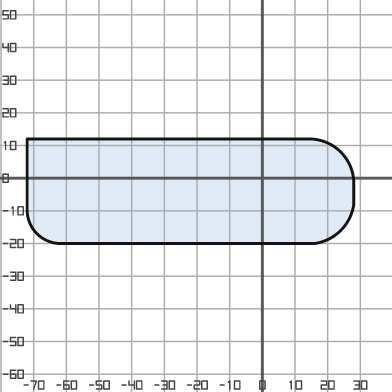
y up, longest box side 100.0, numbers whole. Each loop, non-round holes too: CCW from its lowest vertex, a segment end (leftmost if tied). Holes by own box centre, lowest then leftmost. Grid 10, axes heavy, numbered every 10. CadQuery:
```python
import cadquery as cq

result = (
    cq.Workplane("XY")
    .moveTo(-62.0, -20.0)
    .lineTo(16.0, -20.0)
    .threePointArc((24.0, -16.0), (28.0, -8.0))
    .lineTo(28.0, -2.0)
    .threePointArc((24.0, 8.0), (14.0, 12.0))
    .lineTo(-72.0, 12.0)
    .lineTo(-72.0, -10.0)
    .threePointArc((-69.0, -17.0), (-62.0, -20.0))
    .close()
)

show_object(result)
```